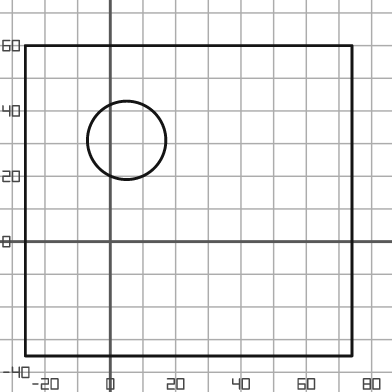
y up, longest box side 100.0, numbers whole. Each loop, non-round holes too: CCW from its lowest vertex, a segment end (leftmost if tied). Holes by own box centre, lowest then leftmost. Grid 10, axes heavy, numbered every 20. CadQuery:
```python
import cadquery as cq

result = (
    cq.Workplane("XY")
    .moveTo(-26.0, -35.0)
    .lineTo(74.0, -35.0)
    .lineTo(74.0, 60.0)
    .lineTo(-26.0, 60.0)
    .close()
    .moveTo(5.0, 31.0)
    .circle(12.0)
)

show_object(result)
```